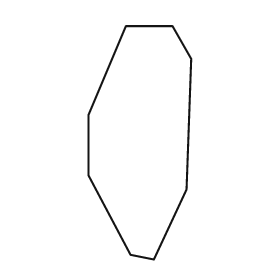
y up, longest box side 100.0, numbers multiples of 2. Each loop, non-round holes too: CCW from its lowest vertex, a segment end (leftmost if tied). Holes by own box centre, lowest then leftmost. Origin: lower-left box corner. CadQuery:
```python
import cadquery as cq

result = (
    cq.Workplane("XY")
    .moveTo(28.0, 0.0)
    .lineTo(42.0, 30.0)
    .lineTo(44.0, 86.0)
    .lineTo(36.0, 100.0)
    .lineTo(16.0, 100.0)
    .lineTo(0.0, 62.0)
    .lineTo(0.0, 36.0)
    .lineTo(18.0, 2.0)
    .close()
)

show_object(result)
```